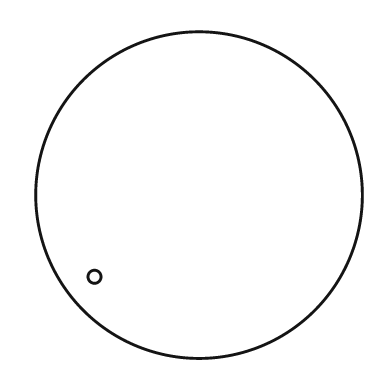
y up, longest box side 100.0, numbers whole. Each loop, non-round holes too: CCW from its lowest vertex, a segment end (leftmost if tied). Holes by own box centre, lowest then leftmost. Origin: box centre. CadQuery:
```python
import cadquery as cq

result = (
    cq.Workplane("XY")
    .moveTo(0.0, 0.0)
    .circle(50.0)
    .moveTo(-32.0, -25.0)
    .circle(2.0)
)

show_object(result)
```